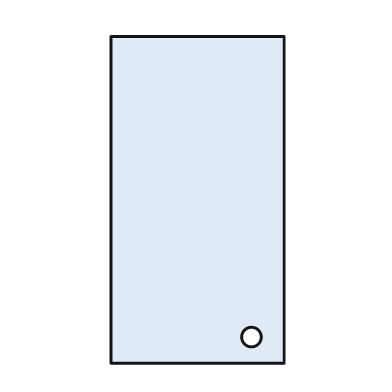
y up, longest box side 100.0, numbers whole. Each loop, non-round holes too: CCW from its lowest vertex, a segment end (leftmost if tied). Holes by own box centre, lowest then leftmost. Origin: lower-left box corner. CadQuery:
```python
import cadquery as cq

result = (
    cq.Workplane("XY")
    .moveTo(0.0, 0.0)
    .lineTo(53.0, 0.0)
    .lineTo(53.0, 100.0)
    .lineTo(0.0, 100.0)
    .close()
    .moveTo(43.0, 8.0)
    .circle(3.0)
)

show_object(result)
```